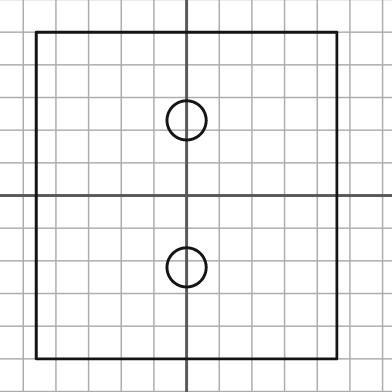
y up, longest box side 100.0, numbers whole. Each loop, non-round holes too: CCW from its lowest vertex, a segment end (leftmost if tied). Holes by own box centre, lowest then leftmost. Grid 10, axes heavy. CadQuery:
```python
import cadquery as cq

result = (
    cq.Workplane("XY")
    .moveTo(-46.0, -50.0)
    .lineTo(46.0, -50.0)
    .lineTo(46.0, 50.0)
    .lineTo(-46.0, 50.0)
    .close()
    .moveTo(0.0, -22.0)
    .circle(6.0)
    .moveTo(0.0, 23.0)
    .circle(6.0)
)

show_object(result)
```